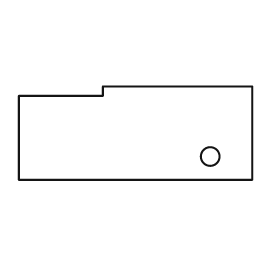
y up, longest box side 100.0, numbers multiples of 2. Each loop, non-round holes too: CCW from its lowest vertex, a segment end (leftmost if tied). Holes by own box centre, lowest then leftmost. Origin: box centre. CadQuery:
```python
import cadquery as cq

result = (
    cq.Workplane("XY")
    .moveTo(-50.0, -20.0)
    .lineTo(50.0, -20.0)
    .lineTo(50.0, 20.0)
    .lineTo(-14.0, 20.0)
    .lineTo(-14.0, 16.0)
    .lineTo(-50.0, 16.0)
    .close()
    .moveTo(32.0, -10.0)
    .circle(4.0)
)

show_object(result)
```